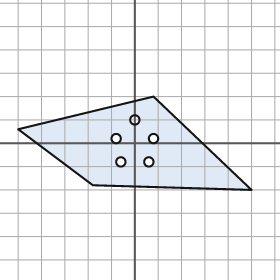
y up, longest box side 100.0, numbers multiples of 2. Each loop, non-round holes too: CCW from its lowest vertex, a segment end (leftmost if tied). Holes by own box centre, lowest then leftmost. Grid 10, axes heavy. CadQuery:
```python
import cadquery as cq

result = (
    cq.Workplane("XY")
    .moveTo(50.0, -20.0)
    .lineTo(8.0, 20.0)
    .lineTo(-50.0, 6.0)
    .lineTo(-18.0, -18.0)
    .close()
    .moveTo(-6.0, -8.0)
    .circle(2.0)
    .moveTo(6.0, -8.0)
    .circle(2.0)
    .moveTo(-8.0, 2.0)
    .circle(2.0)
    .moveTo(8.0, 2.0)
    .circle(2.0)
    .moveTo(0.0, 10.0)
    .circle(2.0)
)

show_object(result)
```